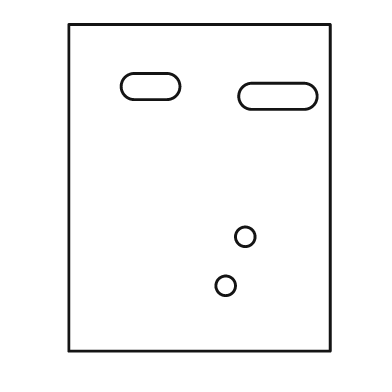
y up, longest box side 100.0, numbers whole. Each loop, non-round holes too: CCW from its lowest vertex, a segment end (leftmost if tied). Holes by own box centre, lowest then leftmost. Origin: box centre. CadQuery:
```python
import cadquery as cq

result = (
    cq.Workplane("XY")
    .moveTo(-40.0, -50.0)
    .lineTo(40.0, -50.0)
    .lineTo(40.0, 50.0)
    .lineTo(-40.0, 50.0)
    .close()
    .moveTo(8.0, -30.0)
    .circle(3.0)
    .moveTo(14.0, -15.0)
    .circle(3.0)
    .moveTo(16.0, 24.0)
    .lineTo(32.0, 24.0)
    .threePointArc((36.0, 28.0), (32.0, 32.0))
    .lineTo(16.0, 32.0)
    .threePointArc((12.0, 28.0), (16.0, 24.0))
    .close()
    .moveTo(-20.0, 27.0)
    .lineTo(-10.0, 27.0)
    .threePointArc((-6.0, 31.0), (-10.0, 35.0))
    .lineTo(-20.0, 35.0)
    .threePointArc((-24.0, 31.0), (-20.0, 27.0))
    .close()
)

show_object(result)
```